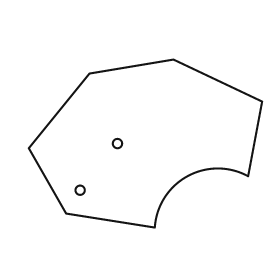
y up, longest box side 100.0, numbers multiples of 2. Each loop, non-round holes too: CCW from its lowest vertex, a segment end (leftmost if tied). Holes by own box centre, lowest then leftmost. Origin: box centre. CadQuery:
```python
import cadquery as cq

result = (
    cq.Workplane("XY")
    .moveTo(4.0, -36.0)
    .threePointArc((18.0, -14.0), (44.0, -14.0))
    .lineTo(50.0, 18.0)
    .lineTo(12.0, 36.0)
    .lineTo(-24.0, 30.0)
    .lineTo(-50.0, -2.0)
    .lineTo(-34.0, -30.0)
    .close()
    .moveTo(-28.0, -20.0)
    .circle(2.0)
    .moveTo(-12.0, 0.0)
    .circle(2.0)
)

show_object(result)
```